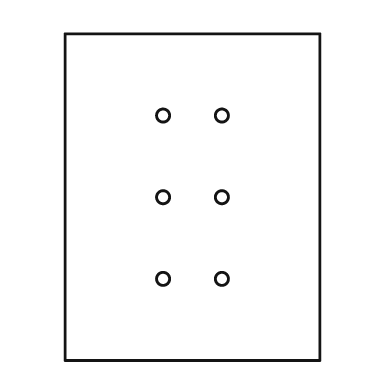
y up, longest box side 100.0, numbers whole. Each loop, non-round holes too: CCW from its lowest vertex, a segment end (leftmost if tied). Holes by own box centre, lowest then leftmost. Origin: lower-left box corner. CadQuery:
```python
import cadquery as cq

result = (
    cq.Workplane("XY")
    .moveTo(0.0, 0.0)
    .lineTo(78.0, 0.0)
    .lineTo(78.0, 100.0)
    .lineTo(0.0, 100.0)
    .close()
    .moveTo(30.0, 25.0)
    .circle(2.0)
    .moveTo(48.0, 25.0)
    .circle(2.0)
    .moveTo(30.0, 50.0)
    .circle(2.0)
    .moveTo(48.0, 50.0)
    .circle(2.0)
    .moveTo(30.0, 75.0)
    .circle(2.0)
    .moveTo(48.0, 75.0)
    .circle(2.0)
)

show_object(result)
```